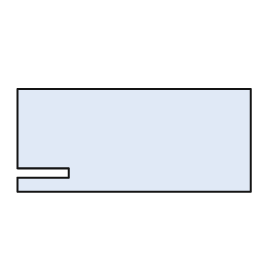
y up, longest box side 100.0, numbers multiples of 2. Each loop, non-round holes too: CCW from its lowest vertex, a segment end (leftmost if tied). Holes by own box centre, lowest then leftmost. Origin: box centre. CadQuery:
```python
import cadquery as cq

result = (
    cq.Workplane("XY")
    .moveTo(-50.0, -22.0)
    .lineTo(50.0, -22.0)
    .lineTo(50.0, 22.0)
    .lineTo(-50.0, 22.0)
    .lineTo(-50.0, -12.0)
    .lineTo(-28.0, -12.0)
    .lineTo(-28.0, -16.0)
    .lineTo(-50.0, -16.0)
    .close()
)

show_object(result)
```